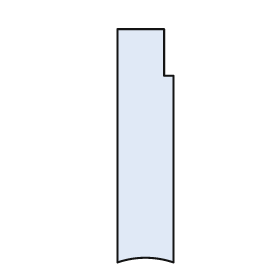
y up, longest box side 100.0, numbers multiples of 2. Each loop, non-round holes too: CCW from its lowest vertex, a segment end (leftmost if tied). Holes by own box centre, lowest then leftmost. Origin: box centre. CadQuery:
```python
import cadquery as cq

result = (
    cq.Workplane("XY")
    .moveTo(-12.0, -50.0)
    .threePointArc((0.0, -48.0), (12.0, -50.0))
    .lineTo(12.0, 30.0)
    .lineTo(8.0, 30.0)
    .lineTo(8.0, 50.0)
    .lineTo(-12.0, 50.0)
    .close()
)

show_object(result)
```